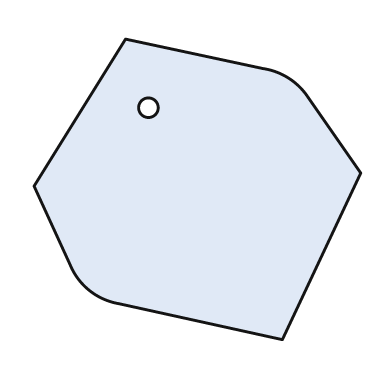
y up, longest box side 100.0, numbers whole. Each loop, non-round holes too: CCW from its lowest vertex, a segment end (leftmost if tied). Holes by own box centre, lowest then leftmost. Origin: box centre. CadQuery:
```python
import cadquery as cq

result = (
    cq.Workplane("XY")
    .moveTo(26.0, -46.0)
    .lineTo(50.0, 5.0)
    .lineTo(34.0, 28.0)
    .threePointArc((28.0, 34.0), (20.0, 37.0))
    .lineTo(-22.0, 46.0)
    .lineTo(-50.0, 1.0)
    .lineTo(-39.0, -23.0)
    .threePointArc((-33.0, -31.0), (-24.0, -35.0))
    .close()
    .moveTo(-15.0, 25.0)
    .circle(3.0)
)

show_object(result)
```